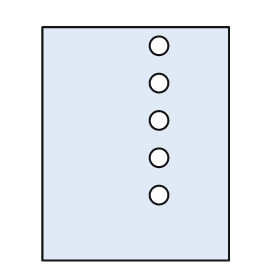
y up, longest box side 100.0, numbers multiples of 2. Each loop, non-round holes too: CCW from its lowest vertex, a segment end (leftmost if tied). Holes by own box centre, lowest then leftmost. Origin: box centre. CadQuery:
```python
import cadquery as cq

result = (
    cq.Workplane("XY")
    .moveTo(-40.0, -50.0)
    .lineTo(40.0, -50.0)
    .lineTo(40.0, 50.0)
    .lineTo(-40.0, 50.0)
    .close()
    .moveTo(10.0, -22.0)
    .circle(4.0)
    .moveTo(10.0, -6.0)
    .circle(4.0)
    .moveTo(10.0, 10.0)
    .circle(4.0)
    .moveTo(10.0, 26.0)
    .circle(4.0)
    .moveTo(10.0, 42.0)
    .circle(4.0)
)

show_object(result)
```